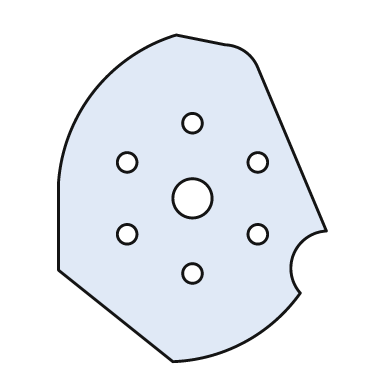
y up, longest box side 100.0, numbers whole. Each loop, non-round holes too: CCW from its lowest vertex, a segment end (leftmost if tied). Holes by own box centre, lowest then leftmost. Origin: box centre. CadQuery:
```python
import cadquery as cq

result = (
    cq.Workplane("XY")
    .moveTo(-6.0, -50.0)
    .threePointArc((16.0, -44.0), (33.0, -29.0))
    .threePointArc((31.0, -17.0), (41.0, -10.0))
    .lineTo(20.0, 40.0)
    .threePointArc((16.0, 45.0), (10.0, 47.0))
    .lineTo(-5.0, 50.0)
    .threePointArc((-30.0, 33.0), (-41.0, 5.0))
    .lineTo(-41.0, -22.0)
    .close()
    .moveTo(0.0, -23.0)
    .circle(3.0)
    .moveTo(-20.0, -11.0)
    .circle(3.0)
    .moveTo(20.0, -11.0)
    .circle(3.0)
    .moveTo(0.0, 0.0)
    .circle(6.0)
    .moveTo(-20.0, 11.0)
    .circle(3.0)
    .moveTo(20.0, 11.0)
    .circle(3.0)
    .moveTo(0.0, 23.0)
    .circle(3.0)
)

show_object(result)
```